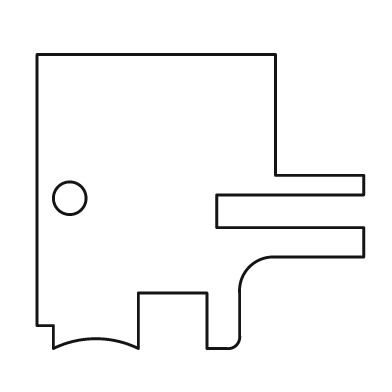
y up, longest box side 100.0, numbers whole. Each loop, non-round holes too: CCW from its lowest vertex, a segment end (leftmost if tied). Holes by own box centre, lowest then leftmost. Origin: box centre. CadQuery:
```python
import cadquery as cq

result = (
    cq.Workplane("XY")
    .moveTo(-45.0, -45.0)
    .threePointArc((-32.0, -42.0), (-19.0, -45.0))
    .lineTo(-19.0, -28.0)
    .lineTo(2.0, -28.0)
    .lineTo(2.0, -45.0)
    .lineTo(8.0, -45.0)
    .threePointArc((11.0, -44.0), (12.0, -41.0))
    .lineTo(12.0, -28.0)
    .threePointArc((15.0, -20.0), (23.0, -17.0))
    .lineTo(50.0, -17.0)
    .lineTo(50.0, -8.0)
    .lineTo(5.0, -8.0)
    .lineTo(5.0, 2.0)
    .lineTo(50.0, 2.0)
    .lineTo(50.0, 8.0)
    .lineTo(23.0, 8.0)
    .lineTo(23.0, 45.0)
    .lineTo(-50.0, 45.0)
    .lineTo(-50.0, -38.0)
    .lineTo(-45.0, -38.0)
    .close()
    .moveTo(-40.0, 1.0)
    .circle(5.0)
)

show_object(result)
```